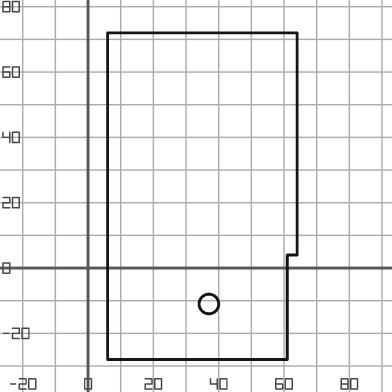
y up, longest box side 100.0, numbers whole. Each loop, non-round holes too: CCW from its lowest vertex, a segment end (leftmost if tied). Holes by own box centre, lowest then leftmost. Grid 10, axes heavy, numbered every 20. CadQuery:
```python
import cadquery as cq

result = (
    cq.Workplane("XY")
    .moveTo(6.0, -28.0)
    .lineTo(61.0, -28.0)
    .lineTo(61.0, 4.0)
    .lineTo(64.0, 4.0)
    .lineTo(64.0, 72.0)
    .lineTo(6.0, 72.0)
    .close()
    .moveTo(37.0, -11.0)
    .circle(3.0)
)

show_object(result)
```